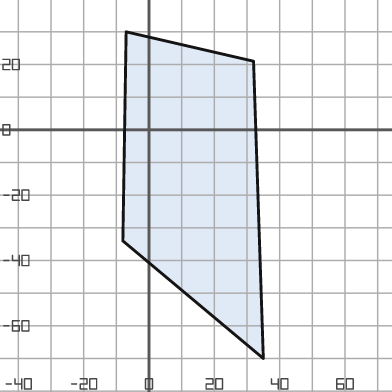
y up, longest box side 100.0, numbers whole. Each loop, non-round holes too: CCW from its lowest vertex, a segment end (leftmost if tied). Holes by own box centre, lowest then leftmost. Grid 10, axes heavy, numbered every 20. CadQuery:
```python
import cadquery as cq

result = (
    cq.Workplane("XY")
    .moveTo(35.0, -70.0)
    .lineTo(32.0, 21.0)
    .lineTo(-7.0, 30.0)
    .lineTo(-8.0, -34.0)
    .close()
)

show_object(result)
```